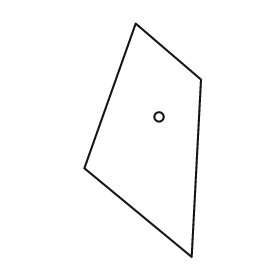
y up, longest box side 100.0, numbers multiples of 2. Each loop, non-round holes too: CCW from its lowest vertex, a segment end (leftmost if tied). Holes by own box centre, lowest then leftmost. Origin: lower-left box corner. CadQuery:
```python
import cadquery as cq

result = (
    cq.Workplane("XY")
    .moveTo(46.0, 0.0)
    .lineTo(50.0, 76.0)
    .lineTo(22.0, 100.0)
    .lineTo(0.0, 38.0)
    .close()
    .moveTo(32.0, 60.0)
    .circle(2.0)
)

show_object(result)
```